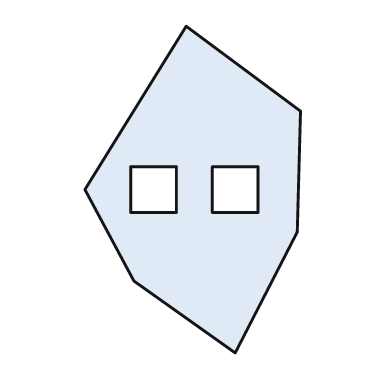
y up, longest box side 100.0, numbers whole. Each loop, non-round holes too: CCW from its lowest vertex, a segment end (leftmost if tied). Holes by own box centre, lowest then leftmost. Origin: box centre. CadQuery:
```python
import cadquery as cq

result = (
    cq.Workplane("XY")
    .moveTo(13.0, -50.0)
    .lineTo(32.0, -13.0)
    .lineTo(33.0, 24.0)
    .lineTo(-2.0, 50.0)
    .lineTo(-33.0, 0.0)
    .lineTo(-18.0, -28.0)
    .close()
    .moveTo(-19.0, -7.0)
    .lineTo(-5.0, -7.0)
    .lineTo(-5.0, 7.0)
    .lineTo(-19.0, 7.0)
    .close()
    .moveTo(6.0, -7.0)
    .lineTo(20.0, -7.0)
    .lineTo(20.0, 7.0)
    .lineTo(6.0, 7.0)
    .close()
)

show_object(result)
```